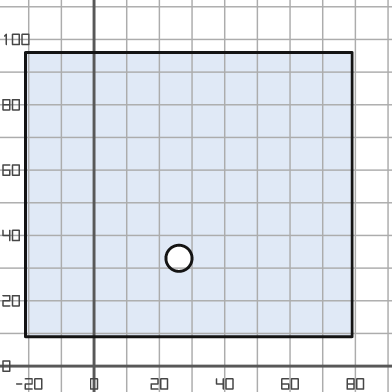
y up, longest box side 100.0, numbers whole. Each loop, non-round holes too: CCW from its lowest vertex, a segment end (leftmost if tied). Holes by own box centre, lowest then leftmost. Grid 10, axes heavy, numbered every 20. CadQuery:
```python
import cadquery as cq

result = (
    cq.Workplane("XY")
    .moveTo(-21.0, 9.0)
    .lineTo(79.0, 9.0)
    .lineTo(79.0, 96.0)
    .lineTo(-21.0, 96.0)
    .close()
    .moveTo(26.0, 33.0)
    .circle(4.0)
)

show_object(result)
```